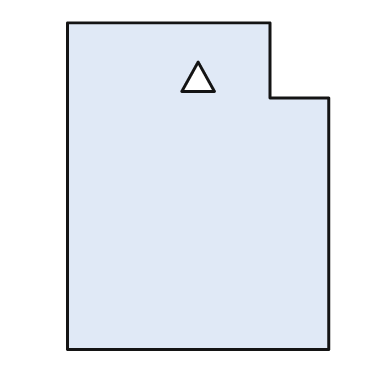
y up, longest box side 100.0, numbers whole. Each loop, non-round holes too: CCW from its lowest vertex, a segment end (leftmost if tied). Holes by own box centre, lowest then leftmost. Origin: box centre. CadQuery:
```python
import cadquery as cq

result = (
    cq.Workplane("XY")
    .moveTo(-40.0, -50.0)
    .lineTo(40.0, -50.0)
    .lineTo(40.0, 27.0)
    .lineTo(22.0, 27.0)
    .lineTo(22.0, 50.0)
    .lineTo(-40.0, 50.0)
    .close()
    .moveTo(-5.0, 29.0)
    .lineTo(5.0, 29.0)
    .lineTo(0.0, 38.0)
    .close()
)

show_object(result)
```